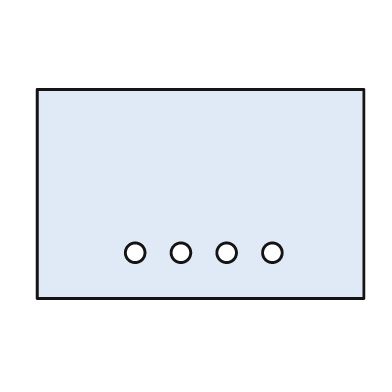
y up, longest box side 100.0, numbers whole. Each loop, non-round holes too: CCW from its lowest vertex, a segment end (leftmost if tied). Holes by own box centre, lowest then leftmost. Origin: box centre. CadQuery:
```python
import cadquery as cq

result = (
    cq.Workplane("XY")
    .moveTo(-50.0, -32.0)
    .lineTo(50.0, -32.0)
    .lineTo(50.0, 32.0)
    .lineTo(-50.0, 32.0)
    .close()
    .moveTo(-20.0, -18.0)
    .circle(3.0)
    .moveTo(-6.0, -18.0)
    .circle(3.0)
    .moveTo(8.0, -18.0)
    .circle(3.0)
    .moveTo(22.0, -18.0)
    .circle(3.0)
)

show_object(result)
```